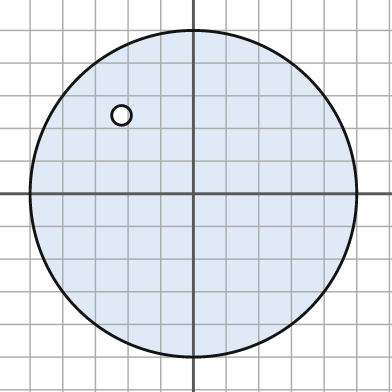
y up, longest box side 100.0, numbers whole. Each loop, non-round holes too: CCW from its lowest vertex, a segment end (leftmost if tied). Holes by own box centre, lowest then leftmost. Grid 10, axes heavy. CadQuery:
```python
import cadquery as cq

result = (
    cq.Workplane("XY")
    .moveTo(0.0, 0.0)
    .circle(50.0)
    .moveTo(-22.0, 24.0)
    .circle(3.0)
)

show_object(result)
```